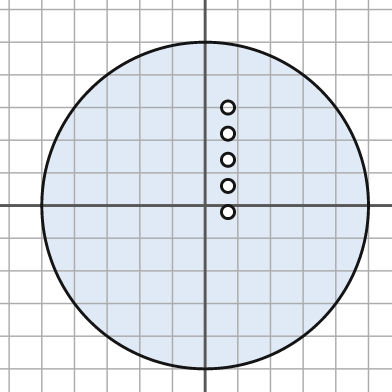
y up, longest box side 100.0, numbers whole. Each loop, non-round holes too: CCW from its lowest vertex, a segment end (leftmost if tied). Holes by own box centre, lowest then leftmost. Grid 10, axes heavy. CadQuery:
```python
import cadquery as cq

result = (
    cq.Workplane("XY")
    .moveTo(0.0, 0.0)
    .circle(50.0)
    .moveTo(7.0, -2.0)
    .circle(2.0)
    .moveTo(7.0, 6.0)
    .circle(2.0)
    .moveTo(7.0, 14.0)
    .circle(2.0)
    .moveTo(7.0, 22.0)
    .circle(2.0)
    .moveTo(7.0, 30.0)
    .circle(2.0)
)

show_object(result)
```